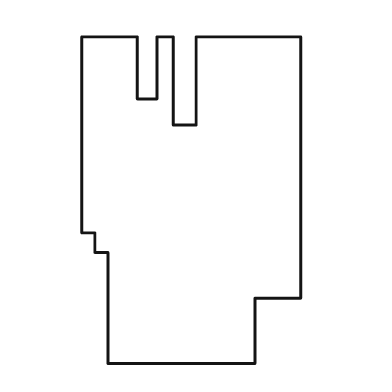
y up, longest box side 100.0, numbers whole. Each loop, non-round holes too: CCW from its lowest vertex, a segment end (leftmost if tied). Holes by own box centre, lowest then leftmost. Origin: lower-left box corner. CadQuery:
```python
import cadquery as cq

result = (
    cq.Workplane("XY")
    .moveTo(8.0, 0.0)
    .lineTo(53.0, 0.0)
    .lineTo(53.0, 20.0)
    .lineTo(67.0, 20.0)
    .lineTo(67.0, 100.0)
    .lineTo(35.0, 100.0)
    .lineTo(35.0, 73.0)
    .lineTo(28.0, 73.0)
    .lineTo(28.0, 100.0)
    .lineTo(23.0, 100.0)
    .lineTo(23.0, 81.0)
    .lineTo(17.0, 81.0)
    .lineTo(17.0, 100.0)
    .lineTo(0.0, 100.0)
    .lineTo(0.0, 40.0)
    .lineTo(4.0, 40.0)
    .lineTo(4.0, 34.0)
    .lineTo(8.0, 34.0)
    .close()
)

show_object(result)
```